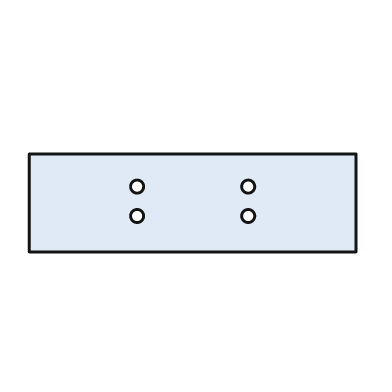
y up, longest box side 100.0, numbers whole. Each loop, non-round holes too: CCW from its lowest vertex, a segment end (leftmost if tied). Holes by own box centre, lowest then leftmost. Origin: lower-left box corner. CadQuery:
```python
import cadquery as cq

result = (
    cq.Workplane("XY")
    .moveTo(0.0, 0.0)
    .lineTo(100.0, 0.0)
    .lineTo(100.0, 30.0)
    .lineTo(0.0, 30.0)
    .close()
    .moveTo(33.0, 11.0)
    .circle(2.0)
    .moveTo(67.0, 11.0)
    .circle(2.0)
    .moveTo(33.0, 20.0)
    .circle(2.0)
    .moveTo(67.0, 20.0)
    .circle(2.0)
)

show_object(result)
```